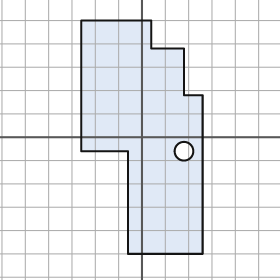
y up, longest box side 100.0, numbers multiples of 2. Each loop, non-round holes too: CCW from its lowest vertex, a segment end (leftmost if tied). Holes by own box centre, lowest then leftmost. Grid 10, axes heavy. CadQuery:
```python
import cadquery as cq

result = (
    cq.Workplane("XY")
    .moveTo(-6.0, -50.0)
    .lineTo(26.0, -50.0)
    .lineTo(26.0, 18.0)
    .lineTo(18.0, 18.0)
    .lineTo(18.0, 38.0)
    .lineTo(4.0, 38.0)
    .lineTo(4.0, 50.0)
    .lineTo(-26.0, 50.0)
    .lineTo(-26.0, -6.0)
    .lineTo(-6.0, -6.0)
    .close()
    .moveTo(18.0, -6.0)
    .circle(4.0)
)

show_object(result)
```